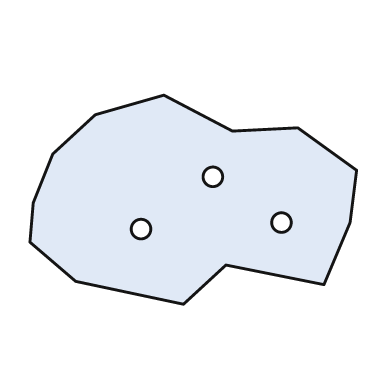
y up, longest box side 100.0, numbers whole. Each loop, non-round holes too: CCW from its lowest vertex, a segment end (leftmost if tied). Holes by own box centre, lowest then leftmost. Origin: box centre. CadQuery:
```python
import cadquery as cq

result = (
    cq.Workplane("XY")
    .moveTo(-3.0, -32.0)
    .lineTo(10.0, -20.0)
    .lineTo(40.0, -26.0)
    .lineTo(48.0, -7.0)
    .lineTo(50.0, 9.0)
    .lineTo(32.0, 22.0)
    .lineTo(12.0, 21.0)
    .lineTo(-9.0, 32.0)
    .lineTo(-30.0, 26.0)
    .lineTo(-43.0, 14.0)
    .lineTo(-49.0, -1.0)
    .lineTo(-50.0, -13.0)
    .lineTo(-36.0, -25.0)
    .close()
    .moveTo(-16.0, -9.0)
    .circle(3.0)
    .moveTo(27.0, -7.0)
    .circle(3.0)
    .moveTo(6.0, 7.0)
    .circle(3.0)
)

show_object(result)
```